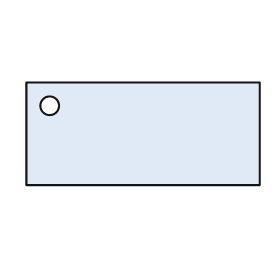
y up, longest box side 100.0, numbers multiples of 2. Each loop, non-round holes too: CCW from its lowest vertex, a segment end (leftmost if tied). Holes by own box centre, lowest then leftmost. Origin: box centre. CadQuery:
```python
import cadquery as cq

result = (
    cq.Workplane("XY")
    .moveTo(-50.0, -22.0)
    .lineTo(50.0, -22.0)
    .lineTo(50.0, 22.0)
    .lineTo(-50.0, 22.0)
    .close()
    .moveTo(-40.0, 12.0)
    .circle(4.0)
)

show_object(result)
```